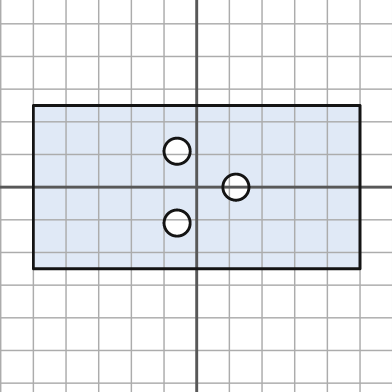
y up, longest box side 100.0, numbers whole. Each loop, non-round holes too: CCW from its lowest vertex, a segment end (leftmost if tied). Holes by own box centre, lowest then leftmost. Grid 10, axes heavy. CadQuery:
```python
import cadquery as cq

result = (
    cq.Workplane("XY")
    .moveTo(-50.0, -25.0)
    .lineTo(50.0, -25.0)
    .lineTo(50.0, 25.0)
    .lineTo(-50.0, 25.0)
    .close()
    .moveTo(-6.0, -11.0)
    .circle(4.0)
    .moveTo(12.0, 0.0)
    .circle(4.0)
    .moveTo(-6.0, 11.0)
    .circle(4.0)
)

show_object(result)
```